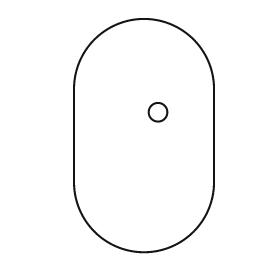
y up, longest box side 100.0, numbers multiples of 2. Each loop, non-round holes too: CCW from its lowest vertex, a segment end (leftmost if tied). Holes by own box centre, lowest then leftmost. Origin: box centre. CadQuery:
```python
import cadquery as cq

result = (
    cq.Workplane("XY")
    .moveTo(-30.0, -20.0)
    .threePointArc((0.0, -50.0), (30.0, -20.0))
    .lineTo(30.0, 20.0)
    .threePointArc((0.0, 50.0), (-30.0, 20.0))
    .close()
    .moveTo(6.0, 10.0)
    .circle(4.0)
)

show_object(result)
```